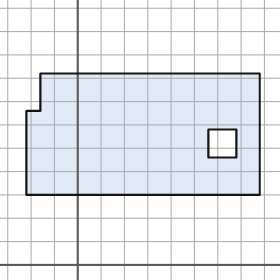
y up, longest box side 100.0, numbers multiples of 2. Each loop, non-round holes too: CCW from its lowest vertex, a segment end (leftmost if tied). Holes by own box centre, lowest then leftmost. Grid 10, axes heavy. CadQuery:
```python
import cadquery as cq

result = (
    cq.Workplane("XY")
    .moveTo(-22.0, 30.0)
    .lineTo(78.0, 30.0)
    .lineTo(78.0, 82.0)
    .lineTo(-16.0, 82.0)
    .lineTo(-16.0, 66.0)
    .lineTo(-22.0, 66.0)
    .close()
    .moveTo(56.0, 46.0)
    .lineTo(68.0, 46.0)
    .lineTo(68.0, 58.0)
    .lineTo(56.0, 58.0)
    .close()
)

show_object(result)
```